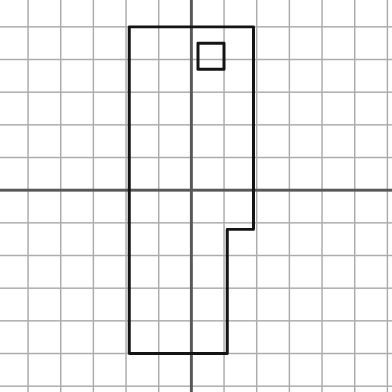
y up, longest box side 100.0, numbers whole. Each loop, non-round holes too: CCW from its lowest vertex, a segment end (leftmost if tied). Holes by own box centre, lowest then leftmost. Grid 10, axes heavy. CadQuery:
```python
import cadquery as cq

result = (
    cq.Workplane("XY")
    .moveTo(-19.0, -50.0)
    .lineTo(11.0, -50.0)
    .lineTo(11.0, -12.0)
    .lineTo(19.0, -12.0)
    .lineTo(19.0, 50.0)
    .lineTo(-19.0, 50.0)
    .close()
    .moveTo(2.0, 37.0)
    .lineTo(10.0, 37.0)
    .lineTo(10.0, 45.0)
    .lineTo(2.0, 45.0)
    .close()
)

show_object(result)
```